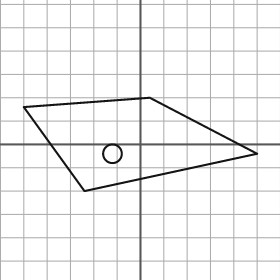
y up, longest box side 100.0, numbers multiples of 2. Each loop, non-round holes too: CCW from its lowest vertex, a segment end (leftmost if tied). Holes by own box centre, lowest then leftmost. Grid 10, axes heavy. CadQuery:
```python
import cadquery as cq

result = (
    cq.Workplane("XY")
    .moveTo(-24.0, -20.0)
    .lineTo(50.0, -4.0)
    .lineTo(4.0, 20.0)
    .lineTo(-50.0, 16.0)
    .close()
    .moveTo(-12.0, -4.0)
    .circle(4.0)
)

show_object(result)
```